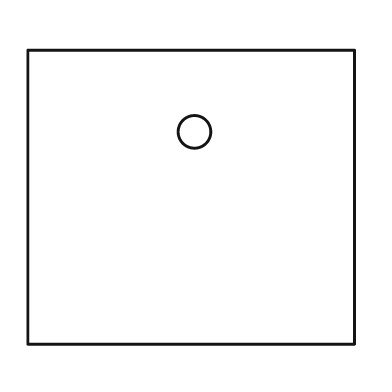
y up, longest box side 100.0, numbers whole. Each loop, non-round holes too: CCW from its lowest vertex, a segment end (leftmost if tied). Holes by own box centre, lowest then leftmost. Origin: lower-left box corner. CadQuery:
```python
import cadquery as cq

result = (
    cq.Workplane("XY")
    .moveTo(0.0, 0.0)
    .lineTo(100.0, 0.0)
    .lineTo(100.0, 90.0)
    .lineTo(0.0, 90.0)
    .close()
    .moveTo(51.0, 65.0)
    .circle(5.0)
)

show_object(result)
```